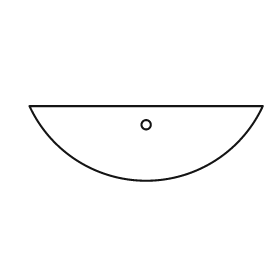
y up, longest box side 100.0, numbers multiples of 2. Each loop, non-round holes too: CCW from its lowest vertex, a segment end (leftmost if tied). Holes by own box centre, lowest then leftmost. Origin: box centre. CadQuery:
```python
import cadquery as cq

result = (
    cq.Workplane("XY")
    .moveTo(-50.0, 16.0)
    .threePointArc((0.0, -16.0), (50.0, 16.0))
    .close()
    .moveTo(0.0, 8.0)
    .circle(2.0)
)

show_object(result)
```